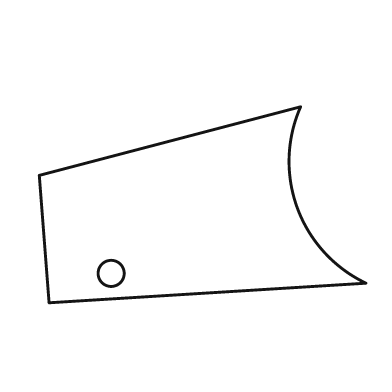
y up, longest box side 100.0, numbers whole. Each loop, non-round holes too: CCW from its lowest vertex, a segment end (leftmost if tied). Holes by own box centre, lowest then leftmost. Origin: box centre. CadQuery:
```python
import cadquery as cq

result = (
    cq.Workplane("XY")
    .moveTo(-47.0, -30.0)
    .lineTo(50.0, -24.0)
    .threePointArc((29.0, -1.0), (30.0, 30.0))
    .lineTo(-50.0, 9.0)
    .close()
    .moveTo(-28.0, -21.0)
    .circle(4.0)
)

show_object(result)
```